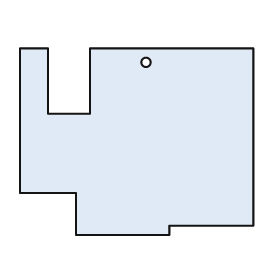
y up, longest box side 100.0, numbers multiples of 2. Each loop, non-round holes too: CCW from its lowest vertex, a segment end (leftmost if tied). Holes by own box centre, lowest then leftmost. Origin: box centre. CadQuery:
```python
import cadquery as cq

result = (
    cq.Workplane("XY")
    .moveTo(-26.0, -40.0)
    .lineTo(14.0, -40.0)
    .lineTo(14.0, -36.0)
    .lineTo(50.0, -36.0)
    .lineTo(50.0, 40.0)
    .lineTo(-20.0, 40.0)
    .lineTo(-20.0, 12.0)
    .lineTo(-38.0, 12.0)
    .lineTo(-38.0, 40.0)
    .lineTo(-50.0, 40.0)
    .lineTo(-50.0, -22.0)
    .lineTo(-26.0, -22.0)
    .close()
    .moveTo(4.0, 34.0)
    .circle(2.0)
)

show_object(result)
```